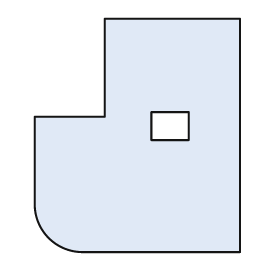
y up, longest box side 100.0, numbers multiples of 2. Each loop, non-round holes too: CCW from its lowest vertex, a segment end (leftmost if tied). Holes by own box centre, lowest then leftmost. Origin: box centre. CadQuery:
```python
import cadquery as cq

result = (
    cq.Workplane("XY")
    .moveTo(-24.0, -50.0)
    .lineTo(44.0, -50.0)
    .lineTo(44.0, 50.0)
    .lineTo(-14.0, 50.0)
    .lineTo(-14.0, 8.0)
    .lineTo(-44.0, 8.0)
    .lineTo(-44.0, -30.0)
    .threePointArc((-38.0, -44.0), (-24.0, -50.0))
    .close()
    .moveTo(6.0, -2.0)
    .lineTo(22.0, -2.0)
    .lineTo(22.0, 10.0)
    .lineTo(6.0, 10.0)
    .close()
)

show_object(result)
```